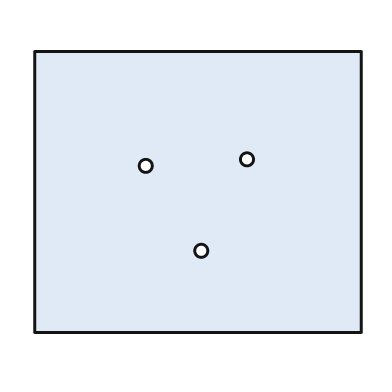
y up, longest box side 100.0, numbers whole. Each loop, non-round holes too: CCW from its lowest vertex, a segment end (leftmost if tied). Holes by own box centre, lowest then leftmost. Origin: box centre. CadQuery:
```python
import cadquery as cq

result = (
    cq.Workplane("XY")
    .moveTo(-50.0, -43.0)
    .lineTo(50.0, -43.0)
    .lineTo(50.0, 43.0)
    .lineTo(-50.0, 43.0)
    .close()
    .moveTo(1.0, -18.0)
    .circle(2.0)
    .moveTo(-16.0, 8.0)
    .circle(2.0)
    .moveTo(15.0, 10.0)
    .circle(2.0)
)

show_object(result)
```